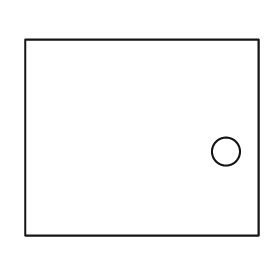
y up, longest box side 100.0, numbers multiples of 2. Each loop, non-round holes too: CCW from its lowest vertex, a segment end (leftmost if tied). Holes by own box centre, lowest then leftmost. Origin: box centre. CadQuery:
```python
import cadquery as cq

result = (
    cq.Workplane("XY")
    .moveTo(-50.0, -42.0)
    .lineTo(50.0, -42.0)
    .lineTo(50.0, 42.0)
    .lineTo(-50.0, 42.0)
    .close()
    .moveTo(36.0, -6.0)
    .circle(6.0)
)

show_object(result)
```